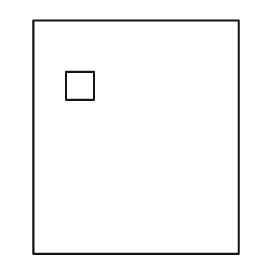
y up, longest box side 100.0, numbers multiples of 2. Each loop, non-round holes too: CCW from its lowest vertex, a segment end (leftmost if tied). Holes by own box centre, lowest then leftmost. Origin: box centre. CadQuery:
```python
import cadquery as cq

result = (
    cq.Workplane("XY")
    .moveTo(-44.0, -50.0)
    .lineTo(44.0, -50.0)
    .lineTo(44.0, 50.0)
    .lineTo(-44.0, 50.0)
    .close()
    .moveTo(-30.0, 16.0)
    .lineTo(-18.0, 16.0)
    .lineTo(-18.0, 28.0)
    .lineTo(-30.0, 28.0)
    .close()
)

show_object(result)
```